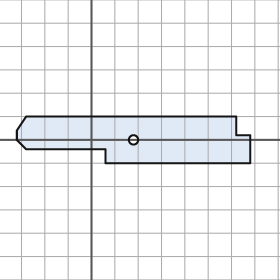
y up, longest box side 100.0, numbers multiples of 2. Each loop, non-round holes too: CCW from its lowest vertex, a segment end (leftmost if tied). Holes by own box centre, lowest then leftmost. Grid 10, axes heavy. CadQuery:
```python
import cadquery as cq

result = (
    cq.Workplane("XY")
    .moveTo(6.0, -10.0)
    .lineTo(68.0, -10.0)
    .lineTo(68.0, 2.0)
    .lineTo(62.0, 2.0)
    .lineTo(62.0, 10.0)
    .lineTo(-28.0, 10.0)
    .lineTo(-32.0, 4.0)
    .lineTo(-32.0, 0.0)
    .lineTo(-28.0, -4.0)
    .lineTo(6.0, -4.0)
    .close()
    .moveTo(18.0, 0.0)
    .circle(2.0)
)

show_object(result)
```